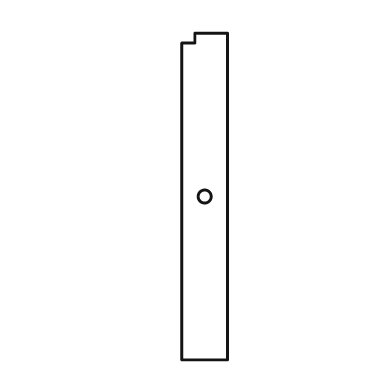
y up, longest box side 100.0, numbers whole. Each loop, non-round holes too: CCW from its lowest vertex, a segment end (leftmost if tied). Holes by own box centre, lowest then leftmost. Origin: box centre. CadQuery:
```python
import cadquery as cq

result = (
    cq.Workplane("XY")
    .moveTo(-7.0, -50.0)
    .lineTo(7.0, -50.0)
    .lineTo(7.0, 50.0)
    .lineTo(-3.0, 50.0)
    .lineTo(-3.0, 47.0)
    .lineTo(-7.0, 47.0)
    .close()
    .moveTo(0.0, 0.0)
    .circle(2.0)
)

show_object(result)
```